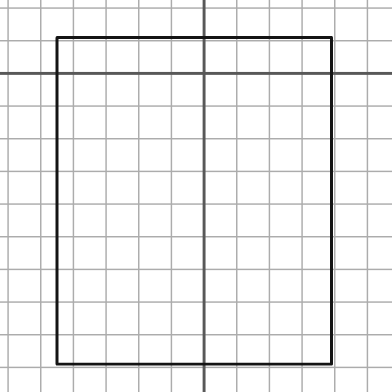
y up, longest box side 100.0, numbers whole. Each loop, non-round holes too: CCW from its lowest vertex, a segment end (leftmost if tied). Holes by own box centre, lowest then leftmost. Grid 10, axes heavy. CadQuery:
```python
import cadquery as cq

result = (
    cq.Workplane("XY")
    .moveTo(-45.0, -89.0)
    .lineTo(39.0, -89.0)
    .lineTo(39.0, 11.0)
    .lineTo(-45.0, 11.0)
    .close()
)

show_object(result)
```